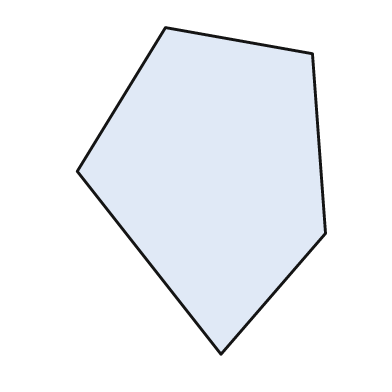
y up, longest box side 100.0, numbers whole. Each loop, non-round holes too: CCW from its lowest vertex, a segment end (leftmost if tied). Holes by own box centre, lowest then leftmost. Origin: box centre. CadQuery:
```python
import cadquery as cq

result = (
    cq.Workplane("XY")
    .moveTo(6.0, -50.0)
    .lineTo(38.0, -13.0)
    .lineTo(34.0, 42.0)
    .lineTo(-11.0, 50.0)
    .lineTo(-38.0, 6.0)
    .close()
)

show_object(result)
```